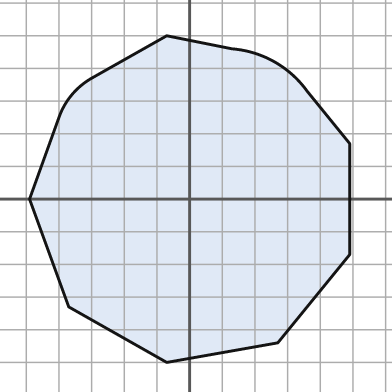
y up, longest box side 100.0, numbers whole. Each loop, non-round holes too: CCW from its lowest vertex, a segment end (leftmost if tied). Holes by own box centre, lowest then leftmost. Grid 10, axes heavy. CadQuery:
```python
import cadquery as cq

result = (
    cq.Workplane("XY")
    .moveTo(-7.0, -50.0)
    .lineTo(27.0, -44.0)
    .lineTo(49.0, -17.0)
    .lineTo(49.0, 17.0)
    .lineTo(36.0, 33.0)
    .threePointArc((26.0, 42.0), (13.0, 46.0))
    .lineTo(-7.0, 50.0)
    .lineTo(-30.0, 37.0)
    .threePointArc((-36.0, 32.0), (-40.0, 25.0))
    .lineTo(-49.0, 0.0)
    .lineTo(-37.0, -33.0)
    .close()
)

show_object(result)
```